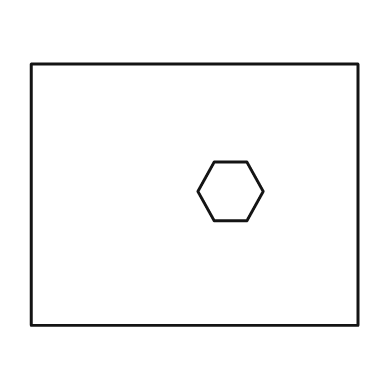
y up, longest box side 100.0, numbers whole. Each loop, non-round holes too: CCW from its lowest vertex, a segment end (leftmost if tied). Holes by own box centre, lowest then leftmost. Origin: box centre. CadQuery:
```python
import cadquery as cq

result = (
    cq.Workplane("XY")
    .moveTo(-50.0, -40.0)
    .lineTo(50.0, -40.0)
    .lineTo(50.0, 40.0)
    .lineTo(-50.0, 40.0)
    .close()
    .moveTo(6.0, -8.0)
    .lineTo(16.0, -8.0)
    .lineTo(21.0, 1.0)
    .lineTo(16.0, 10.0)
    .lineTo(6.0, 10.0)
    .lineTo(1.0, 1.0)
    .close()
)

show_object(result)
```